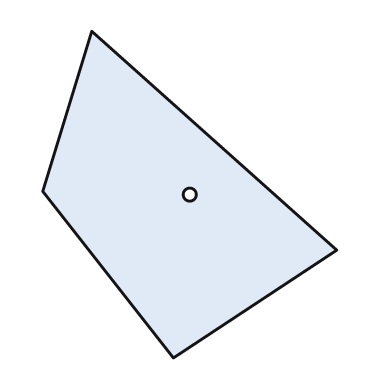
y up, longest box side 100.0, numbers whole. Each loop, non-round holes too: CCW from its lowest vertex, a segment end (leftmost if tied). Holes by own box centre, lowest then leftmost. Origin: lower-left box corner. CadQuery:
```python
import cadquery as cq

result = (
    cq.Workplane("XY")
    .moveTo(40.0, 0.0)
    .lineTo(90.0, 33.0)
    .lineTo(15.0, 100.0)
    .lineTo(0.0, 51.0)
    .close()
    .moveTo(45.0, 50.0)
    .circle(2.0)
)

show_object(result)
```